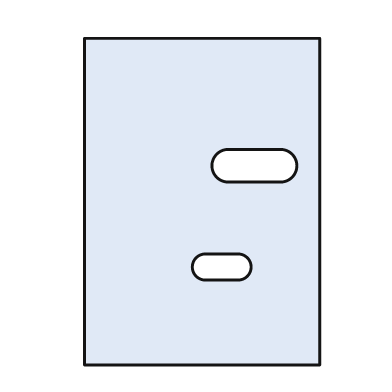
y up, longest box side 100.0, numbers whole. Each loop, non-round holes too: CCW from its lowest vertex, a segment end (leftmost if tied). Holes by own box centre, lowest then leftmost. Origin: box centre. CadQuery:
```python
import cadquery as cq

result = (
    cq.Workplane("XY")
    .moveTo(-36.0, -50.0)
    .lineTo(36.0, -50.0)
    .lineTo(36.0, 50.0)
    .lineTo(-36.0, 50.0)
    .close()
    .moveTo(1.0, -24.0)
    .lineTo(11.0, -24.0)
    .threePointArc((15.0, -20.0), (11.0, -16.0))
    .lineTo(1.0, -16.0)
    .threePointArc((-3.0, -20.0), (1.0, -24.0))
    .close()
    .moveTo(8.0, 6.0)
    .lineTo(24.0, 6.0)
    .threePointArc((29.0, 11.0), (24.0, 16.0))
    .lineTo(8.0, 16.0)
    .threePointArc((3.0, 11.0), (8.0, 6.0))
    .close()
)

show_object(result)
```